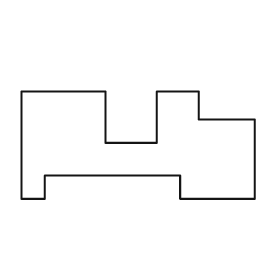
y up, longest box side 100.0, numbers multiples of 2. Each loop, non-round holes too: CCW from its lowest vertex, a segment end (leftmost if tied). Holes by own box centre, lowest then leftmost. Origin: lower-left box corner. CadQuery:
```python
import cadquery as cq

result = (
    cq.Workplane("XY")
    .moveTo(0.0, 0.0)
    .lineTo(10.0, 0.0)
    .lineTo(10.0, 10.0)
    .lineTo(68.0, 10.0)
    .lineTo(68.0, 0.0)
    .lineTo(100.0, 0.0)
    .lineTo(100.0, 34.0)
    .lineTo(76.0, 34.0)
    .lineTo(76.0, 46.0)
    .lineTo(58.0, 46.0)
    .lineTo(58.0, 24.0)
    .lineTo(36.0, 24.0)
    .lineTo(36.0, 46.0)
    .lineTo(0.0, 46.0)
    .close()
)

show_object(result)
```